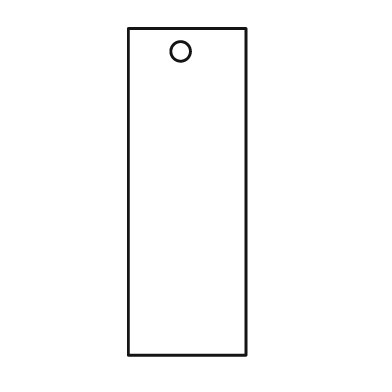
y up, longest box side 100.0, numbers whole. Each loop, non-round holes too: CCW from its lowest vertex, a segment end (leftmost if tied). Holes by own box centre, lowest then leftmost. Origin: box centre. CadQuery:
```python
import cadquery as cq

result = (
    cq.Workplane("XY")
    .moveTo(-18.0, -50.0)
    .lineTo(18.0, -50.0)
    .lineTo(18.0, 50.0)
    .lineTo(-18.0, 50.0)
    .close()
    .moveTo(-2.0, 43.0)
    .circle(3.0)
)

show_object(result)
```